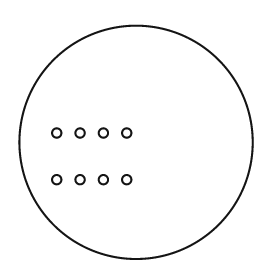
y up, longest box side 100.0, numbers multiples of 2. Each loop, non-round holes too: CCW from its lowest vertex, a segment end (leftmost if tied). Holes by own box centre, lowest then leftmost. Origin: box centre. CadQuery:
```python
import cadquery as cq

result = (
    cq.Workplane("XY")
    .moveTo(0.0, 0.0)
    .circle(50.0)
    .moveTo(-34.0, -16.0)
    .circle(2.0)
    .moveTo(-24.0, -16.0)
    .circle(2.0)
    .moveTo(-14.0, -16.0)
    .circle(2.0)
    .moveTo(-4.0, -16.0)
    .circle(2.0)
    .moveTo(-34.0, 4.0)
    .circle(2.0)
    .moveTo(-24.0, 4.0)
    .circle(2.0)
    .moveTo(-14.0, 4.0)
    .circle(2.0)
    .moveTo(-4.0, 4.0)
    .circle(2.0)
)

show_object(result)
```